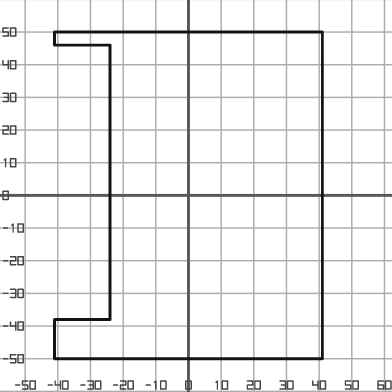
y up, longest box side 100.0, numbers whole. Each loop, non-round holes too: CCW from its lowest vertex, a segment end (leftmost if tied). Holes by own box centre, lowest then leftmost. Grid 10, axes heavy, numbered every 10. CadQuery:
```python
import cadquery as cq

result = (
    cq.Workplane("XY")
    .moveTo(-41.0, -50.0)
    .lineTo(41.0, -50.0)
    .lineTo(41.0, 50.0)
    .lineTo(-41.0, 50.0)
    .lineTo(-41.0, 46.0)
    .lineTo(-24.0, 46.0)
    .lineTo(-24.0, -38.0)
    .lineTo(-41.0, -38.0)
    .close()
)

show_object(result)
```